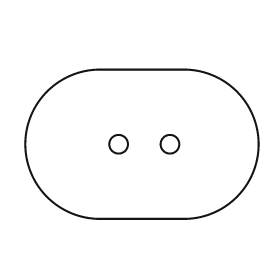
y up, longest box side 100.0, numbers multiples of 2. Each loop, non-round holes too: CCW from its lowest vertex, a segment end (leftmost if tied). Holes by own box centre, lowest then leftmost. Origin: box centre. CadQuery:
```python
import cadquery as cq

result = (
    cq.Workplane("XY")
    .moveTo(-18.0, -32.0)
    .lineTo(18.0, -32.0)
    .threePointArc((50.0, 0.0), (18.0, 32.0))
    .lineTo(-18.0, 32.0)
    .threePointArc((-50.0, 0.0), (-18.0, -32.0))
    .close()
    .moveTo(-10.0, 0.0)
    .circle(4.0)
    .moveTo(12.0, 0.0)
    .circle(4.0)
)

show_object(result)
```